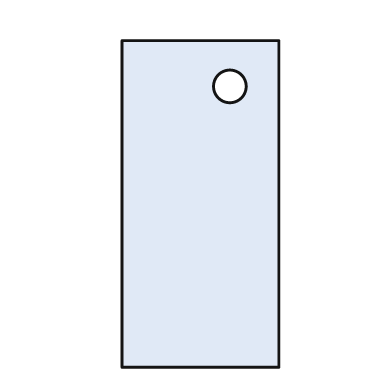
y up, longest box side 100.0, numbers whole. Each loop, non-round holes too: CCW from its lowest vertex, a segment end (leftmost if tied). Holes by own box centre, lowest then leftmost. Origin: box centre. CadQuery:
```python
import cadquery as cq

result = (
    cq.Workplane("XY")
    .moveTo(-24.0, -50.0)
    .lineTo(24.0, -50.0)
    .lineTo(24.0, 50.0)
    .lineTo(-24.0, 50.0)
    .close()
    .moveTo(9.0, 36.0)
    .circle(5.0)
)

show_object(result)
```